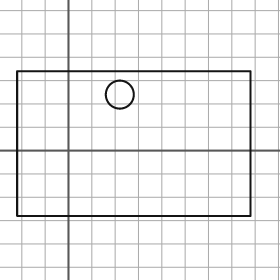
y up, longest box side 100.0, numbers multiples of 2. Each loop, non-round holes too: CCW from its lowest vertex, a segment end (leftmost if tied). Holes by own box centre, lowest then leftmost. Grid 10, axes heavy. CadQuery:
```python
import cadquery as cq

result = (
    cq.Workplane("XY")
    .moveTo(-22.0, -28.0)
    .lineTo(78.0, -28.0)
    .lineTo(78.0, 34.0)
    .lineTo(-22.0, 34.0)
    .close()
    .moveTo(22.0, 24.0)
    .circle(6.0)
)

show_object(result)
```